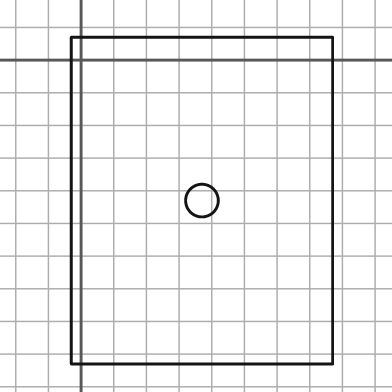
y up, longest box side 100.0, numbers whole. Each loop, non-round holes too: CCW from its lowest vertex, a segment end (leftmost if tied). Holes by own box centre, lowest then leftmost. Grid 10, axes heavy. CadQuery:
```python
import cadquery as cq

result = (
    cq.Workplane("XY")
    .moveTo(-3.0, -93.0)
    .lineTo(77.0, -93.0)
    .lineTo(77.0, 7.0)
    .lineTo(-3.0, 7.0)
    .close()
    .moveTo(37.0, -43.0)
    .circle(5.0)
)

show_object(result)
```